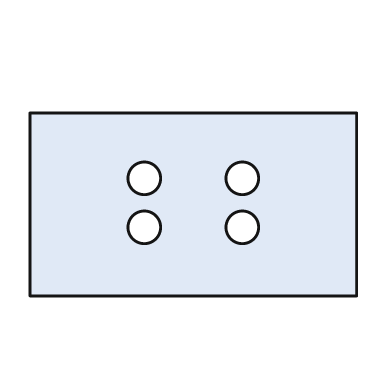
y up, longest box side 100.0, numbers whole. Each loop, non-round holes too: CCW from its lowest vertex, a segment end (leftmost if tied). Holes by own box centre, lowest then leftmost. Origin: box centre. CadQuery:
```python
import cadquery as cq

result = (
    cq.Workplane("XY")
    .moveTo(-50.0, -28.0)
    .lineTo(50.0, -28.0)
    .lineTo(50.0, 28.0)
    .lineTo(-50.0, 28.0)
    .close()
    .moveTo(-15.0, -7.0)
    .circle(5.0)
    .moveTo(15.0, -7.0)
    .circle(5.0)
    .moveTo(-15.0, 8.0)
    .circle(5.0)
    .moveTo(15.0, 8.0)
    .circle(5.0)
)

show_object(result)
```